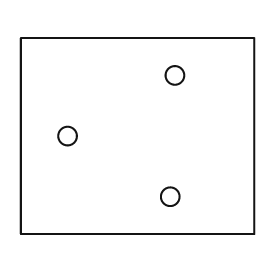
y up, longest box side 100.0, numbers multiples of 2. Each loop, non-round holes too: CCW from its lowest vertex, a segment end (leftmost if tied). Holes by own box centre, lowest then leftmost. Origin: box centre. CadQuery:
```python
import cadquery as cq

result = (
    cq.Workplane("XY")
    .moveTo(-50.0, -42.0)
    .lineTo(50.0, -42.0)
    .lineTo(50.0, 42.0)
    .lineTo(-50.0, 42.0)
    .close()
    .moveTo(14.0, -26.0)
    .circle(4.0)
    .moveTo(-30.0, 0.0)
    .circle(4.0)
    .moveTo(16.0, 26.0)
    .circle(4.0)
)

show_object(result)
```